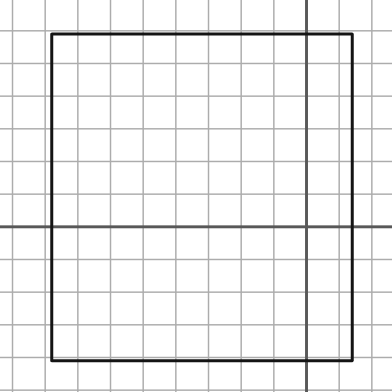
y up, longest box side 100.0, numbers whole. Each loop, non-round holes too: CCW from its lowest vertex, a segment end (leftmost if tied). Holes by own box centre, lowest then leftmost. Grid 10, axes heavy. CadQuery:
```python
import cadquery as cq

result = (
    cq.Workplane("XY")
    .moveTo(-78.0, -41.0)
    .lineTo(14.0, -41.0)
    .lineTo(14.0, 59.0)
    .lineTo(-78.0, 59.0)
    .close()
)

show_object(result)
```